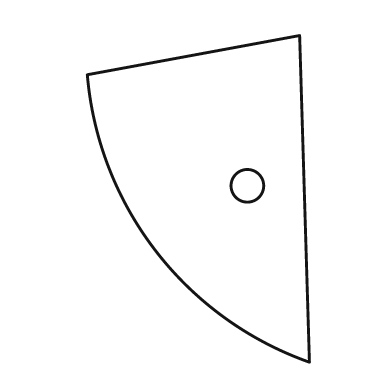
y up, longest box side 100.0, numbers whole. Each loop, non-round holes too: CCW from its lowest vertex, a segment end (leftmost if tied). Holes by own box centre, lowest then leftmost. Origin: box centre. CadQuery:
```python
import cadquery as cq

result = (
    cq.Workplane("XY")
    .moveTo(34.0, -50.0)
    .lineTo(31.0, 50.0)
    .lineTo(-34.0, 38.0)
    .threePointArc((-13.0, -16.0), (34.0, -50.0))
    .close()
    .moveTo(15.0, 4.0)
    .circle(5.0)
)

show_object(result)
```